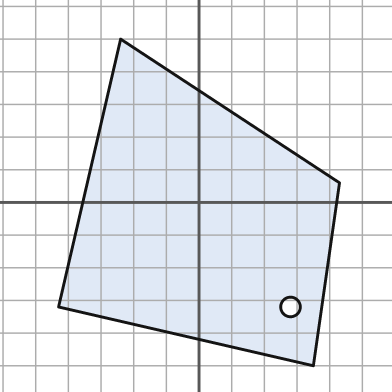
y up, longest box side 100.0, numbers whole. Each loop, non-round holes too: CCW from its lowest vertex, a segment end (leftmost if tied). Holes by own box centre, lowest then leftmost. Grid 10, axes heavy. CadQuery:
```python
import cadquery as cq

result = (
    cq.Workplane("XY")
    .moveTo(35.0, -50.0)
    .lineTo(43.0, 6.0)
    .lineTo(-24.0, 50.0)
    .lineTo(-43.0, -32.0)
    .close()
    .moveTo(28.0, -32.0)
    .circle(3.0)
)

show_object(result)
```